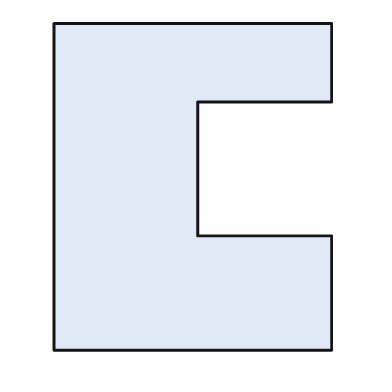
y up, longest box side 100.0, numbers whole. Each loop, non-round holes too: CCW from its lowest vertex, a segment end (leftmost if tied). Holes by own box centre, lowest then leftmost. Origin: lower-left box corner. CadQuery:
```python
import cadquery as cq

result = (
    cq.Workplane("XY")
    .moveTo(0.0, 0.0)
    .lineTo(85.0, 0.0)
    .lineTo(85.0, 35.0)
    .lineTo(44.0, 35.0)
    .lineTo(44.0, 76.0)
    .lineTo(85.0, 76.0)
    .lineTo(85.0, 100.0)
    .lineTo(0.0, 100.0)
    .close()
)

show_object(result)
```